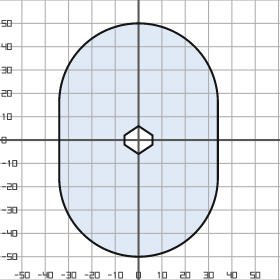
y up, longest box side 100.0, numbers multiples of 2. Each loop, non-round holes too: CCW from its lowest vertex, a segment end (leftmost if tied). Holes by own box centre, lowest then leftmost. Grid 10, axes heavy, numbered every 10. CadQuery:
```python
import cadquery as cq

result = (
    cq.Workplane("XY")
    .moveTo(-34.0, -16.0)
    .threePointArc((0.0, -50.0), (34.0, -16.0))
    .lineTo(34.0, 16.0)
    .threePointArc((0.0, 50.0), (-34.0, 16.0))
    .close()
    .moveTo(0.0, -6.0)
    .lineTo(6.0, -2.0)
    .lineTo(6.0, 2.0)
    .lineTo(0.0, 6.0)
    .lineTo(-6.0, 2.0)
    .lineTo(-6.0, -2.0)
    .close()
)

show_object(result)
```